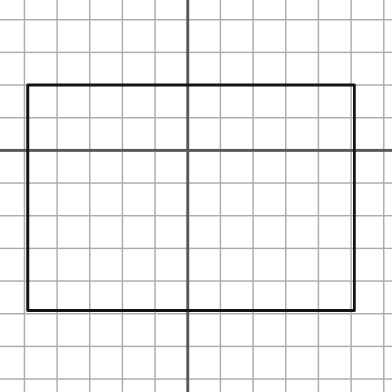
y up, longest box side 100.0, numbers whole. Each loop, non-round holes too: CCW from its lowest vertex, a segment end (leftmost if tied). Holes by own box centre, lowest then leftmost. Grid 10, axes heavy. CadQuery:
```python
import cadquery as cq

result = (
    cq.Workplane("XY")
    .moveTo(-49.0, -49.0)
    .lineTo(51.0, -49.0)
    .lineTo(51.0, 20.0)
    .lineTo(-49.0, 20.0)
    .close()
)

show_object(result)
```